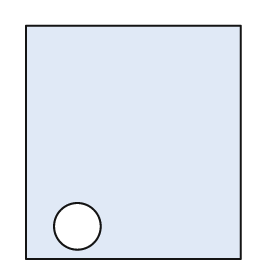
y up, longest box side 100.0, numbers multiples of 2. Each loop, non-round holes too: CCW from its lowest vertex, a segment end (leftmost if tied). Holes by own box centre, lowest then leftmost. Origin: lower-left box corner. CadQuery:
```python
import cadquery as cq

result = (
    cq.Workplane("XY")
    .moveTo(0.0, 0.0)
    .lineTo(92.0, 0.0)
    .lineTo(92.0, 100.0)
    .lineTo(0.0, 100.0)
    .close()
    .moveTo(22.0, 14.0)
    .circle(10.0)
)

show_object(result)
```